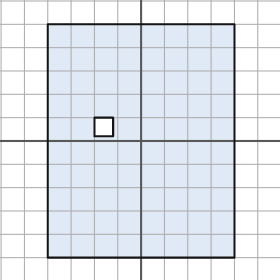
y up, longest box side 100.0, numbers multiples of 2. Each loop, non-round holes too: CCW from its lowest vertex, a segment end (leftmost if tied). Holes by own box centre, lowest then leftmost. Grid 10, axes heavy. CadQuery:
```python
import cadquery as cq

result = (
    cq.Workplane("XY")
    .moveTo(-40.0, -50.0)
    .lineTo(40.0, -50.0)
    .lineTo(40.0, 50.0)
    .lineTo(-40.0, 50.0)
    .close()
    .moveTo(-20.0, 2.0)
    .lineTo(-12.0, 2.0)
    .lineTo(-12.0, 10.0)
    .lineTo(-20.0, 10.0)
    .close()
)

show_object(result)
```